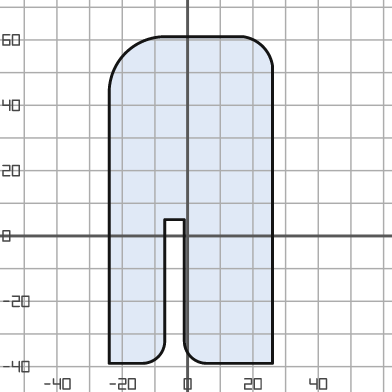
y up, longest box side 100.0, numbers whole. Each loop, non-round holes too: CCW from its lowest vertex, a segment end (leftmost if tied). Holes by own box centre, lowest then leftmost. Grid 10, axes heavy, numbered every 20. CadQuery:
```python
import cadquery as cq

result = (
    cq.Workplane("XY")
    .moveTo(-24.0, -39.0)
    .lineTo(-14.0, -39.0)
    .threePointArc((-9.0, -37.0), (-7.0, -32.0))
    .lineTo(-7.0, 5.0)
    .lineTo(-1.0, 5.0)
    .lineTo(-1.0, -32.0)
    .threePointArc((1.0, -37.0), (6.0, -39.0))
    .lineTo(26.0, -39.0)
    .lineTo(26.0, 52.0)
    .threePointArc((23.0, 58.0), (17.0, 61.0))
    .lineTo(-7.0, 61.0)
    .threePointArc((-19.0, 56.0), (-24.0, 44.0))
    .close()
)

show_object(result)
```